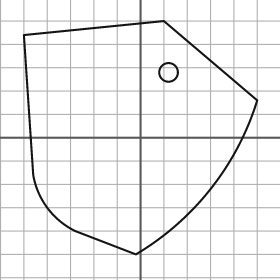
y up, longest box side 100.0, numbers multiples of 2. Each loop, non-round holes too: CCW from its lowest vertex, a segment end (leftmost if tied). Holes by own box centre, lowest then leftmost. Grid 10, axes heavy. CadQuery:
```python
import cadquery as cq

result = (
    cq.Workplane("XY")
    .moveTo(-2.0, -50.0)
    .threePointArc((30.0, -22.0), (50.0, 16.0))
    .lineTo(10.0, 50.0)
    .lineTo(-50.0, 44.0)
    .lineTo(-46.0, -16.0)
    .threePointArc((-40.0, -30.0), (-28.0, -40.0))
    .close()
    .moveTo(12.0, 28.0)
    .circle(4.0)
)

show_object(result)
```